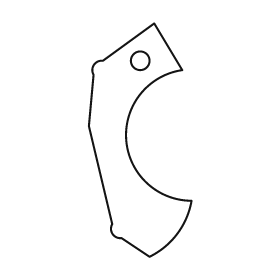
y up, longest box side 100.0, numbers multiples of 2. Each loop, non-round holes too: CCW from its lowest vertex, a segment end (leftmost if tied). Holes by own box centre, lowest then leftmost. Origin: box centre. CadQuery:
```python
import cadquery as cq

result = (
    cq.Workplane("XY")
    .moveTo(4.0, -50.0)
    .threePointArc((16.0, -40.0), (22.0, -26.0))
    .threePointArc((-6.0, 0.0), (18.0, 30.0))
    .lineTo(6.0, 50.0)
    .lineTo(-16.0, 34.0)
    .threePointArc((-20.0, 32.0), (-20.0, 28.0))
    .lineTo(-22.0, 6.0)
    .lineTo(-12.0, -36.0)
    .threePointArc((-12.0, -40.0), (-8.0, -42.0))
    .close()
    .moveTo(0.0, 34.0)
    .circle(4.0)
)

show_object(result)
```